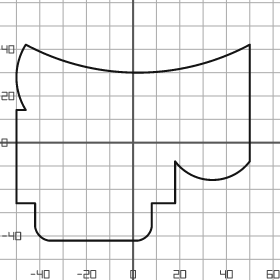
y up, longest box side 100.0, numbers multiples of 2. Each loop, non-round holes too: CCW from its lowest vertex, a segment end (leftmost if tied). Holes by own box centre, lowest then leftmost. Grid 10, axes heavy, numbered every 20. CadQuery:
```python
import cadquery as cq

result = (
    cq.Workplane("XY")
    .moveTo(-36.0, -42.0)
    .lineTo(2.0, -42.0)
    .threePointArc((6.0, -40.0), (8.0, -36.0))
    .lineTo(8.0, -26.0)
    .lineTo(18.0, -26.0)
    .lineTo(18.0, -8.0)
    .threePointArc((34.0, -16.0), (50.0, -8.0))
    .lineTo(50.0, 42.0)
    .threePointArc((2.0, 30.0), (-46.0, 42.0))
    .threePointArc((-50.0, 28.0), (-46.0, 14.0))
    .lineTo(-50.0, 14.0)
    .lineTo(-50.0, -26.0)
    .lineTo(-42.0, -26.0)
    .lineTo(-42.0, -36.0)
    .threePointArc((-40.0, -40.0), (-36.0, -42.0))
    .close()
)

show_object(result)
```